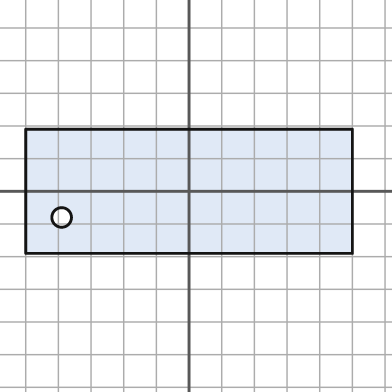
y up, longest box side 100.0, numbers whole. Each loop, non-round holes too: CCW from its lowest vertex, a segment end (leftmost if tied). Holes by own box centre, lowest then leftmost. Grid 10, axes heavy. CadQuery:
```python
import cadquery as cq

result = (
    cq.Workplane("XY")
    .moveTo(-50.0, -19.0)
    .lineTo(50.0, -19.0)
    .lineTo(50.0, 19.0)
    .lineTo(-50.0, 19.0)
    .close()
    .moveTo(-39.0, -8.0)
    .circle(3.0)
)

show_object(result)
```